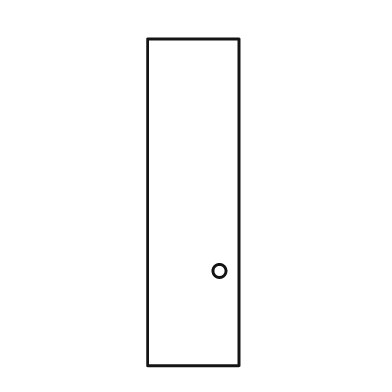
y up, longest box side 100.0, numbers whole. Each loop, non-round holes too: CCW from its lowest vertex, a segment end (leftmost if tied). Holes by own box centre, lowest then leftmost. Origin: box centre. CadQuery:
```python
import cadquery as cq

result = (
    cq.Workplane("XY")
    .moveTo(-14.0, -50.0)
    .lineTo(14.0, -50.0)
    .lineTo(14.0, 50.0)
    .lineTo(-14.0, 50.0)
    .close()
    .moveTo(8.0, -21.0)
    .circle(2.0)
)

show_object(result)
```